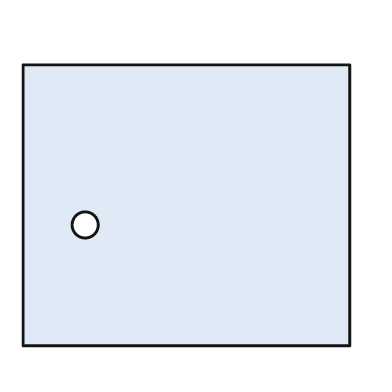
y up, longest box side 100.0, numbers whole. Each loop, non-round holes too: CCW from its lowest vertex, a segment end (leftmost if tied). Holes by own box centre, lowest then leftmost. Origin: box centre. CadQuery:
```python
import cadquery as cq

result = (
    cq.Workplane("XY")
    .moveTo(-50.0, -43.0)
    .lineTo(50.0, -43.0)
    .lineTo(50.0, 43.0)
    .lineTo(-50.0, 43.0)
    .close()
    .moveTo(-31.0, -6.0)
    .circle(4.0)
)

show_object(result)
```